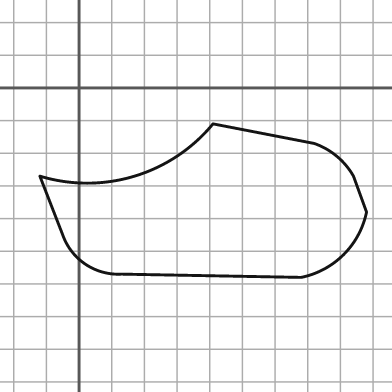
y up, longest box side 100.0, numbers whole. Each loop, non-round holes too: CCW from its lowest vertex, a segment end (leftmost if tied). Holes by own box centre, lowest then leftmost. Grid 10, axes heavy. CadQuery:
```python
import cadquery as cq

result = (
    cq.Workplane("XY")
    .moveTo(68.0, -58.0)
    .threePointArc((81.0, -51.0), (88.0, -38.0))
    .lineTo(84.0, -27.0)
    .threePointArc((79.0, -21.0), (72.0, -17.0))
    .lineTo(41.0, -11.0)
    .threePointArc((17.0, -27.0), (-12.0, -27.0))
    .lineTo(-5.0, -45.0)
    .threePointArc((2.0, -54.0), (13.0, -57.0))
    .close()
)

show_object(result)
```